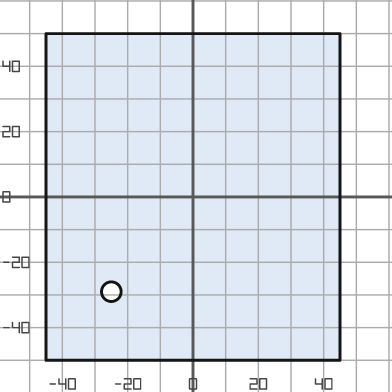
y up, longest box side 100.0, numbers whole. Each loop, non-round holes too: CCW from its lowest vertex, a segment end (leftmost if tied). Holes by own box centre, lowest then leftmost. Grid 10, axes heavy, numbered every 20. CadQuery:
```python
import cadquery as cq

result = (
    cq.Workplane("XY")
    .moveTo(-45.0, -50.0)
    .lineTo(45.0, -50.0)
    .lineTo(45.0, 50.0)
    .lineTo(-45.0, 50.0)
    .close()
    .moveTo(-25.0, -29.0)
    .circle(3.0)
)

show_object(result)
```